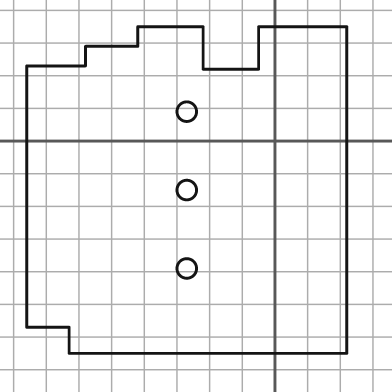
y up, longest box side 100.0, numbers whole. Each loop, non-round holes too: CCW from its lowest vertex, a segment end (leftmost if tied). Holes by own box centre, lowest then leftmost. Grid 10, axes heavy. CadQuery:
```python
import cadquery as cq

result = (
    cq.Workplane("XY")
    .moveTo(-63.0, -65.0)
    .lineTo(22.0, -65.0)
    .lineTo(22.0, 35.0)
    .lineTo(-5.0, 35.0)
    .lineTo(-5.0, 22.0)
    .lineTo(-22.0, 22.0)
    .lineTo(-22.0, 35.0)
    .lineTo(-42.0, 35.0)
    .lineTo(-42.0, 29.0)
    .lineTo(-58.0, 29.0)
    .lineTo(-58.0, 23.0)
    .lineTo(-76.0, 23.0)
    .lineTo(-76.0, -57.0)
    .lineTo(-63.0, -57.0)
    .close()
    .moveTo(-27.0, -39.0)
    .circle(3.0)
    .moveTo(-27.0, -15.0)
    .circle(3.0)
    .moveTo(-27.0, 9.0)
    .circle(3.0)
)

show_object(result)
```